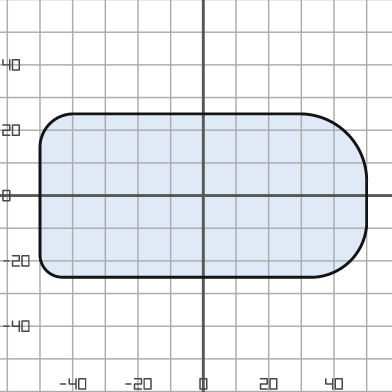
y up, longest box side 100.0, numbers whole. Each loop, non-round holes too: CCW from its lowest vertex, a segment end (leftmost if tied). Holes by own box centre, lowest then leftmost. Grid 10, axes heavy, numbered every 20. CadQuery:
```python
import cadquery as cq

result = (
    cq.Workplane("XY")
    .moveTo(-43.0, -25.0)
    .lineTo(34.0, -25.0)
    .threePointArc((45.0, -20.0), (50.0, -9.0))
    .lineTo(50.0, 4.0)
    .threePointArc((44.0, 19.0), (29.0, 25.0))
    .lineTo(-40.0, 25.0)
    .threePointArc((-47.0, 22.0), (-50.0, 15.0))
    .lineTo(-50.0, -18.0)
    .threePointArc((-48.0, -23.0), (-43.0, -25.0))
    .close()
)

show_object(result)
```